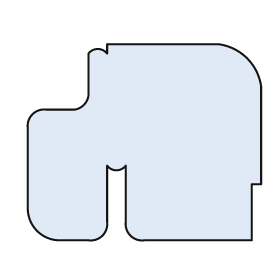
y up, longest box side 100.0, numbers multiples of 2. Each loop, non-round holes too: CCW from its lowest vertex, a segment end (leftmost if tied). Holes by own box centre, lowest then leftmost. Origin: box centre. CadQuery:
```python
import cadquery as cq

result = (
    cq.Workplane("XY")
    .moveTo(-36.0, -42.0)
    .lineTo(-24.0, -42.0)
    .threePointArc((-18.0, -40.0), (-16.0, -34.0))
    .lineTo(-16.0, -10.0)
    .threePointArc((-12.0, -12.0), (-8.0, -10.0))
    .lineTo(-8.0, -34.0)
    .threePointArc((-6.0, -40.0), (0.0, -42.0))
    .lineTo(46.0, -42.0)
    .lineTo(46.0, -18.0)
    .lineTo(50.0, -18.0)
    .lineTo(50.0, 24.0)
    .threePointArc((44.0, 36.0), (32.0, 42.0))
    .lineTo(-16.0, 42.0)
    .lineTo(-16.0, 38.0)
    .threePointArc((-20.0, 40.0), (-24.0, 38.0))
    .lineTo(-24.0, 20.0)
    .threePointArc((-26.0, 16.0), (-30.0, 14.0))
    .lineTo(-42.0, 14.0)
    .threePointArc((-48.0, 12.0), (-50.0, 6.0))
    .lineTo(-50.0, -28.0)
    .threePointArc((-46.0, -38.0), (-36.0, -42.0))
    .close()
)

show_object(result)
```